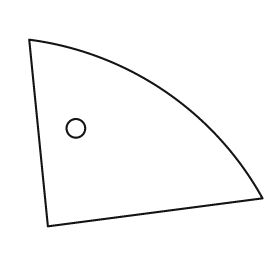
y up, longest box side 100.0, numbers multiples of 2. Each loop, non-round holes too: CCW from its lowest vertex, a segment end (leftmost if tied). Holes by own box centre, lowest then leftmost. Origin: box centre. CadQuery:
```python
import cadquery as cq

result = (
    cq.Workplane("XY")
    .moveTo(-42.0, -40.0)
    .lineTo(50.0, -28.0)
    .threePointArc((8.0, 18.0), (-50.0, 40.0))
    .close()
    .moveTo(-30.0, 2.0)
    .circle(4.0)
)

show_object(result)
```